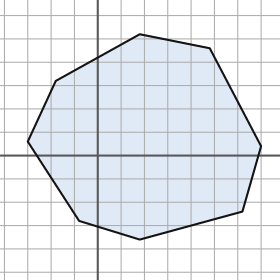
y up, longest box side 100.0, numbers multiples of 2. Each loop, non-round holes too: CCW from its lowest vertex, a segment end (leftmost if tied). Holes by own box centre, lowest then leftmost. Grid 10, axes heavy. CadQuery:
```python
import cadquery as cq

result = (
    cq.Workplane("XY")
    .moveTo(18.0, -36.0)
    .lineTo(62.0, -24.0)
    .lineTo(70.0, 4.0)
    .lineTo(48.0, 46.0)
    .lineTo(18.0, 52.0)
    .lineTo(-18.0, 32.0)
    .lineTo(-30.0, 6.0)
    .lineTo(-8.0, -28.0)
    .close()
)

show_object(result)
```